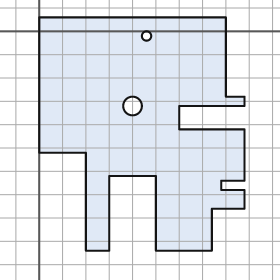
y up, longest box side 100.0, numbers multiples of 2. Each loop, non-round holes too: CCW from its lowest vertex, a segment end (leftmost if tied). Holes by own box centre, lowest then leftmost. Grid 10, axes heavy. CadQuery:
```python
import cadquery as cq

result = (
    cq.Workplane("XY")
    .moveTo(20.0, -94.0)
    .lineTo(30.0, -94.0)
    .lineTo(30.0, -62.0)
    .lineTo(50.0, -62.0)
    .lineTo(50.0, -94.0)
    .lineTo(74.0, -94.0)
    .lineTo(74.0, -76.0)
    .lineTo(88.0, -76.0)
    .lineTo(88.0, -68.0)
    .lineTo(78.0, -68.0)
    .lineTo(78.0, -64.0)
    .lineTo(88.0, -64.0)
    .lineTo(88.0, -42.0)
    .lineTo(60.0, -42.0)
    .lineTo(60.0, -32.0)
    .lineTo(88.0, -32.0)
    .lineTo(88.0, -28.0)
    .lineTo(80.0, -28.0)
    .lineTo(80.0, 6.0)
    .lineTo(0.0, 6.0)
    .lineTo(0.0, -52.0)
    .lineTo(20.0, -52.0)
    .close()
    .moveTo(40.0, -32.0)
    .circle(4.0)
    .moveTo(46.0, -2.0)
    .circle(2.0)
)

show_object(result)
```